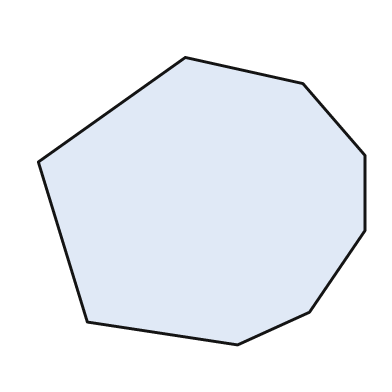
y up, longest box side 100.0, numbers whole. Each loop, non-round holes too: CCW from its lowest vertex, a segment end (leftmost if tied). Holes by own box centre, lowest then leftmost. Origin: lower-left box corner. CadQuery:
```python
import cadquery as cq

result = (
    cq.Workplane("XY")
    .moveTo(61.0, 0.0)
    .lineTo(83.0, 10.0)
    .lineTo(100.0, 35.0)
    .lineTo(100.0, 58.0)
    .lineTo(81.0, 80.0)
    .lineTo(45.0, 88.0)
    .lineTo(0.0, 56.0)
    .lineTo(15.0, 7.0)
    .close()
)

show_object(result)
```